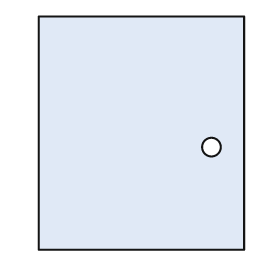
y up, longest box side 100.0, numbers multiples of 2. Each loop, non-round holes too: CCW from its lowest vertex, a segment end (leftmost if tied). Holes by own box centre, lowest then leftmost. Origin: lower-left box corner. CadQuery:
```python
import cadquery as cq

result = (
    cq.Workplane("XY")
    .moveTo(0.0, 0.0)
    .lineTo(88.0, 0.0)
    .lineTo(88.0, 100.0)
    .lineTo(0.0, 100.0)
    .close()
    .moveTo(74.0, 44.0)
    .circle(4.0)
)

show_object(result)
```